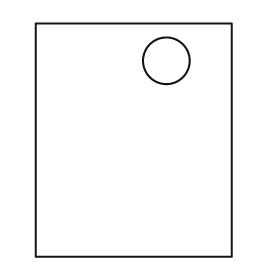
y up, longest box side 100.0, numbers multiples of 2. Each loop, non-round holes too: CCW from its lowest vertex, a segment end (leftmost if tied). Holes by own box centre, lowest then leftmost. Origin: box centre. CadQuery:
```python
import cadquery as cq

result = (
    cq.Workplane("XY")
    .moveTo(-42.0, -50.0)
    .lineTo(42.0, -50.0)
    .lineTo(42.0, 50.0)
    .lineTo(-42.0, 50.0)
    .close()
    .moveTo(14.0, 34.0)
    .circle(10.0)
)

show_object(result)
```